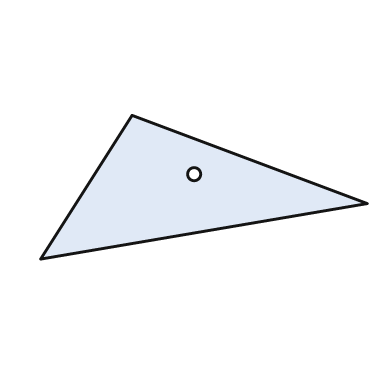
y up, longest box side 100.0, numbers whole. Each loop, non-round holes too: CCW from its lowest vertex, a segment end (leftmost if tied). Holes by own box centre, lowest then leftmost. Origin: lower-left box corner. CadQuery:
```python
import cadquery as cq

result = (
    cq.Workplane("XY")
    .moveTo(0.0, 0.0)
    .lineTo(100.0, 17.0)
    .lineTo(28.0, 44.0)
    .close()
    .moveTo(47.0, 26.0)
    .circle(2.0)
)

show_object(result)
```